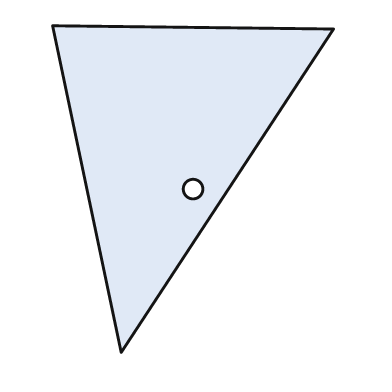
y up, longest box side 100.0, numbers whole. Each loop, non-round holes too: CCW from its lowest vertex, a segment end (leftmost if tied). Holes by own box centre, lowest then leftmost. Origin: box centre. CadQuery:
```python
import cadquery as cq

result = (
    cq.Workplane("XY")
    .moveTo(-22.0, -50.0)
    .lineTo(43.0, 49.0)
    .lineTo(-43.0, 50.0)
    .close()
    .moveTo(0.0, 0.0)
    .circle(3.0)
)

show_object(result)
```